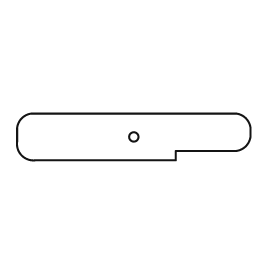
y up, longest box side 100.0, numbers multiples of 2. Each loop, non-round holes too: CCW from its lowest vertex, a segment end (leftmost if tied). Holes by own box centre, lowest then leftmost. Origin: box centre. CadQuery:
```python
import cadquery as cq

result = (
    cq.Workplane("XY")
    .moveTo(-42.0, -10.0)
    .lineTo(18.0, -10.0)
    .lineTo(18.0, -6.0)
    .lineTo(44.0, -6.0)
    .threePointArc((48.0, -4.0), (50.0, 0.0))
    .lineTo(50.0, 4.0)
    .threePointArc((48.0, 8.0), (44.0, 10.0))
    .lineTo(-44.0, 10.0)
    .threePointArc((-48.0, 8.0), (-50.0, 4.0))
    .lineTo(-50.0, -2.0)
    .threePointArc((-48.0, -8.0), (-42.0, -10.0))
    .close()
    .moveTo(0.0, 0.0)
    .circle(2.0)
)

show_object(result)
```